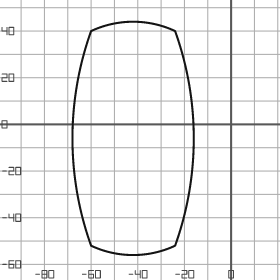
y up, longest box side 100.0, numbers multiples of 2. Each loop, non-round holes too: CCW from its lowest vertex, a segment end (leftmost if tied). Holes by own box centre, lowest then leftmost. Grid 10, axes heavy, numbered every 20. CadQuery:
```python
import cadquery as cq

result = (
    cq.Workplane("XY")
    .moveTo(-60.0, -52.0)
    .threePointArc((-42.0, -56.0), (-24.0, -52.0))
    .threePointArc((-16.0, -6.0), (-24.0, 40.0))
    .threePointArc((-42.0, 44.0), (-60.0, 40.0))
    .threePointArc((-68.0, -6.0), (-60.0, -52.0))
    .close()
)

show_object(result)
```